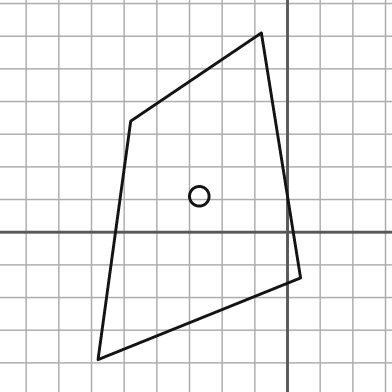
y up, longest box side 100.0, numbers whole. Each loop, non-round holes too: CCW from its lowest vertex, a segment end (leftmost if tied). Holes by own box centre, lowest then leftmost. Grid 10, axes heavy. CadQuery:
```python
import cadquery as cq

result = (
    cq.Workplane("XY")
    .moveTo(-58.0, -39.0)
    .lineTo(4.0, -14.0)
    .lineTo(-8.0, 61.0)
    .lineTo(-48.0, 34.0)
    .close()
    .moveTo(-27.0, 11.0)
    .circle(3.0)
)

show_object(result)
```